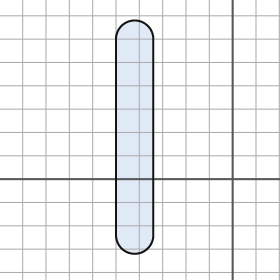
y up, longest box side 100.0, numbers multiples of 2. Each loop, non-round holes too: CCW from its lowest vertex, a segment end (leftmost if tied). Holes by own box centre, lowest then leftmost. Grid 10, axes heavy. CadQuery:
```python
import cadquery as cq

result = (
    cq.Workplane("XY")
    .moveTo(-50.0, -24.0)
    .threePointArc((-42.0, -32.0), (-34.0, -24.0))
    .lineTo(-34.0, 60.0)
    .threePointArc((-42.0, 68.0), (-50.0, 60.0))
    .close()
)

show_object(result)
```